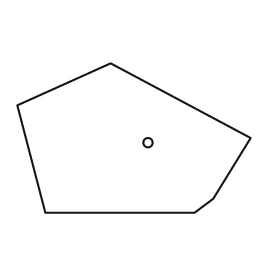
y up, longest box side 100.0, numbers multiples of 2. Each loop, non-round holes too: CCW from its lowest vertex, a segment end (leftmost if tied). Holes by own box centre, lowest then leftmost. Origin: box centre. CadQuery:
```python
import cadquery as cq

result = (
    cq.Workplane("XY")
    .moveTo(-38.0, -32.0)
    .lineTo(26.0, -32.0)
    .lineTo(34.0, -26.0)
    .lineTo(50.0, 0.0)
    .lineTo(-10.0, 32.0)
    .lineTo(-50.0, 14.0)
    .close()
    .moveTo(6.0, -2.0)
    .circle(2.0)
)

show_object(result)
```